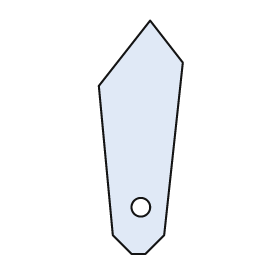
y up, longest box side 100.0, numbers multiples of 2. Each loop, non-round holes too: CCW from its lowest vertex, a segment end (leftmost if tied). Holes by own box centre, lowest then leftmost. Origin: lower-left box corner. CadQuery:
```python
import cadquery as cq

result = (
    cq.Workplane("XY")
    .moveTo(14.0, 0.0)
    .lineTo(20.0, 0.0)
    .lineTo(28.0, 8.0)
    .lineTo(36.0, 82.0)
    .lineTo(22.0, 100.0)
    .lineTo(0.0, 72.0)
    .lineTo(6.0, 8.0)
    .close()
    .moveTo(18.0, 20.0)
    .circle(4.0)
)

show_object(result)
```